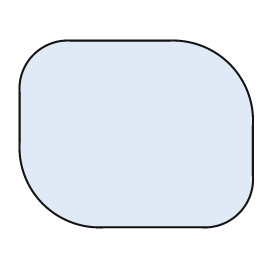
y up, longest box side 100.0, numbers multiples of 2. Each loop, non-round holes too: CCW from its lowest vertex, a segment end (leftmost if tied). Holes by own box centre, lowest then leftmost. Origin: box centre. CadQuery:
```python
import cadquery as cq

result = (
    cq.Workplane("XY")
    .moveTo(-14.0, -40.0)
    .lineTo(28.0, -40.0)
    .threePointArc((44.0, -34.0), (50.0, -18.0))
    .lineTo(50.0, 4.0)
    .threePointArc((40.0, 30.0), (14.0, 40.0))
    .lineTo(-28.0, 40.0)
    .threePointArc((-44.0, 34.0), (-50.0, 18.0))
    .lineTo(-50.0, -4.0)
    .threePointArc((-40.0, -30.0), (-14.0, -40.0))
    .close()
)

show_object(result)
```